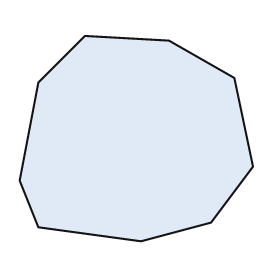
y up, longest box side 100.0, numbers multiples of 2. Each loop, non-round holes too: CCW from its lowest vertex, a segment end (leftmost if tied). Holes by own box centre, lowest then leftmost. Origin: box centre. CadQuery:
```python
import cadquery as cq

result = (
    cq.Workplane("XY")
    .moveTo(2.0, -44.0)
    .lineTo(32.0, -36.0)
    .lineTo(50.0, -12.0)
    .lineTo(42.0, 26.0)
    .lineTo(14.0, 42.0)
    .lineTo(-22.0, 44.0)
    .lineTo(-42.0, 24.0)
    .lineTo(-50.0, -18.0)
    .lineTo(-42.0, -38.0)
    .close()
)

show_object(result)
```